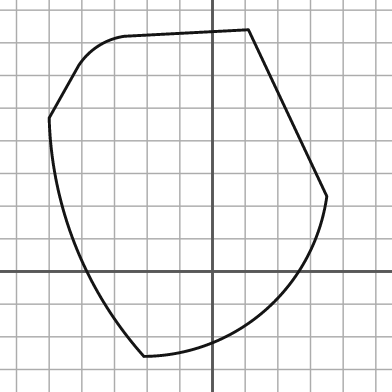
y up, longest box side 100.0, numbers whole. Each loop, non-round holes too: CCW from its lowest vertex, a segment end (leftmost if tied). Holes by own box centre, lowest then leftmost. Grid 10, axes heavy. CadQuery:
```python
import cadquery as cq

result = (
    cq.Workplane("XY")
    .moveTo(-21.0, -26.0)
    .threePointArc((16.0, -12.0), (35.0, 23.0))
    .lineTo(11.0, 74.0)
    .lineTo(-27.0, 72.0)
    .threePointArc((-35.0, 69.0), (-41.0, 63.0))
    .lineTo(-50.0, 47.0)
    .threePointArc((-42.0, 8.0), (-21.0, -26.0))
    .close()
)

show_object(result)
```